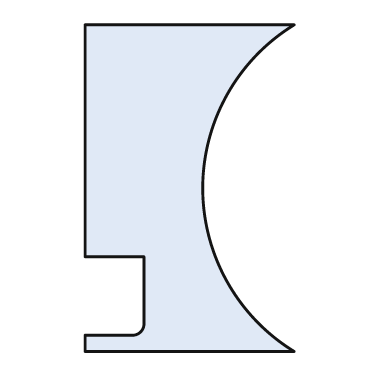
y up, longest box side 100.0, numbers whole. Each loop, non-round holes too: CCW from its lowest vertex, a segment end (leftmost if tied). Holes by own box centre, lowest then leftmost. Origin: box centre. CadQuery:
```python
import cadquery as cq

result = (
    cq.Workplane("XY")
    .moveTo(-32.0, -50.0)
    .lineTo(32.0, -50.0)
    .threePointArc((4.0, 0.0), (32.0, 50.0))
    .lineTo(-32.0, 50.0)
    .lineTo(-32.0, -21.0)
    .lineTo(-14.0, -21.0)
    .lineTo(-14.0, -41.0)
    .threePointArc((-15.0, -44.0), (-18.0, -45.0))
    .lineTo(-32.0, -45.0)
    .close()
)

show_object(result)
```